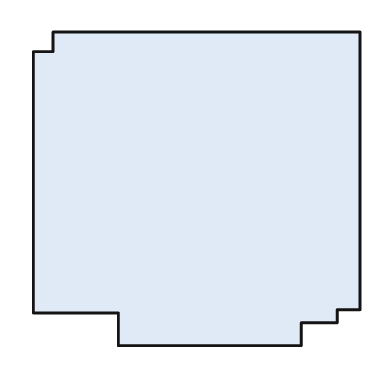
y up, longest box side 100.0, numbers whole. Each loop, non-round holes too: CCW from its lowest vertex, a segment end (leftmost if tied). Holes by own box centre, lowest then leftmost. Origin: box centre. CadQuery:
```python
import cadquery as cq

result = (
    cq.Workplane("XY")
    .moveTo(-24.0, -48.0)
    .lineTo(32.0, -48.0)
    .lineTo(32.0, -41.0)
    .lineTo(43.0, -41.0)
    .lineTo(43.0, -37.0)
    .lineTo(50.0, -37.0)
    .lineTo(50.0, 48.0)
    .lineTo(-44.0, 48.0)
    .lineTo(-44.0, 42.0)
    .lineTo(-50.0, 42.0)
    .lineTo(-50.0, -38.0)
    .lineTo(-24.0, -38.0)
    .close()
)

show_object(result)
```